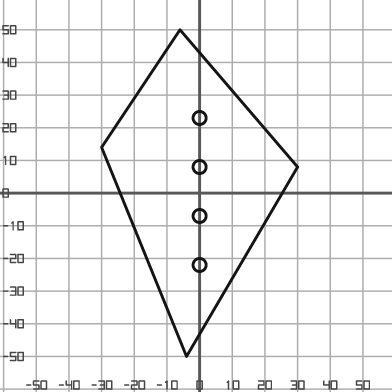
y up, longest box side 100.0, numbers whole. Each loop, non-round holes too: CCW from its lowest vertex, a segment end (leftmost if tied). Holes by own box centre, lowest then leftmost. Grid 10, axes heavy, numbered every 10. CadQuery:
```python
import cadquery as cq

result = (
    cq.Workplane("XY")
    .moveTo(-4.0, -50.0)
    .lineTo(30.0, 8.0)
    .lineTo(-6.0, 50.0)
    .lineTo(-30.0, 14.0)
    .close()
    .moveTo(0.0, -22.0)
    .circle(2.0)
    .moveTo(0.0, -7.0)
    .circle(2.0)
    .moveTo(0.0, 8.0)
    .circle(2.0)
    .moveTo(0.0, 23.0)
    .circle(2.0)
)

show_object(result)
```